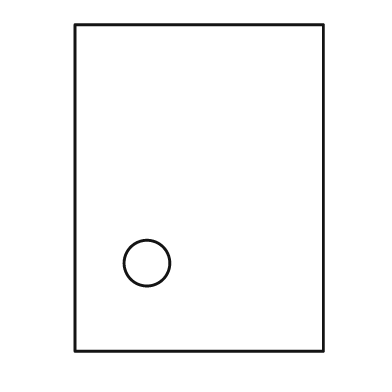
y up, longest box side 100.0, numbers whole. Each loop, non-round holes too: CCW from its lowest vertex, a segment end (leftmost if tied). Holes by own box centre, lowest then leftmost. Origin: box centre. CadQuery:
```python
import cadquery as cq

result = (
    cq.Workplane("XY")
    .moveTo(-38.0, -50.0)
    .lineTo(38.0, -50.0)
    .lineTo(38.0, 50.0)
    .lineTo(-38.0, 50.0)
    .close()
    .moveTo(-16.0, -23.0)
    .circle(7.0)
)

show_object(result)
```